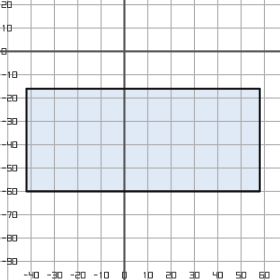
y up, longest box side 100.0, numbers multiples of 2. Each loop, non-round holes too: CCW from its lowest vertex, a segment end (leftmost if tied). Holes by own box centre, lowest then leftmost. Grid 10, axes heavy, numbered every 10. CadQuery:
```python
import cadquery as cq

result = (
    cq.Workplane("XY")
    .moveTo(-42.0, -60.0)
    .lineTo(58.0, -60.0)
    .lineTo(58.0, -16.0)
    .lineTo(-42.0, -16.0)
    .close()
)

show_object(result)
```